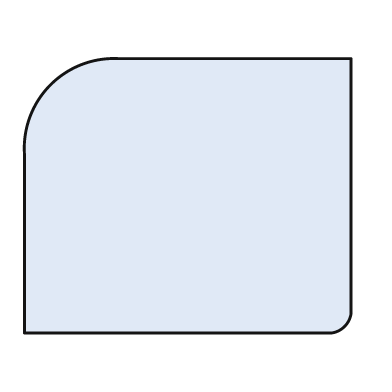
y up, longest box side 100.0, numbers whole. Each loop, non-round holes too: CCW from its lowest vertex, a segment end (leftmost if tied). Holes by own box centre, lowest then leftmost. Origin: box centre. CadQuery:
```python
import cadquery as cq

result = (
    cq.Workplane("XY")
    .moveTo(-50.0, -42.0)
    .lineTo(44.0, -42.0)
    .threePointArc((48.0, -40.0), (50.0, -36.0))
    .lineTo(50.0, 42.0)
    .lineTo(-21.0, 42.0)
    .threePointArc((-42.0, 34.0), (-50.0, 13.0))
    .close()
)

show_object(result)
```